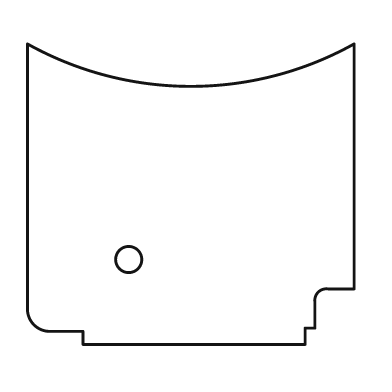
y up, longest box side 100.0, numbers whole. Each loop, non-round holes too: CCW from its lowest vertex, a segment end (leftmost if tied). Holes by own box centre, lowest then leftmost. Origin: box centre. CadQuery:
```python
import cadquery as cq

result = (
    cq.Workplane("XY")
    .moveTo(-33.0, -46.0)
    .lineTo(35.0, -46.0)
    .lineTo(35.0, -41.0)
    .lineTo(38.0, -41.0)
    .lineTo(38.0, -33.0)
    .threePointArc((39.0, -30.0), (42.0, -29.0))
    .lineTo(50.0, -29.0)
    .lineTo(50.0, 46.0)
    .threePointArc((0.0, 33.0), (-50.0, 46.0))
    .lineTo(-50.0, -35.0)
    .threePointArc((-48.0, -40.0), (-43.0, -42.0))
    .lineTo(-33.0, -42.0)
    .close()
    .moveTo(-19.0, -20.0)
    .circle(4.0)
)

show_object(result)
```